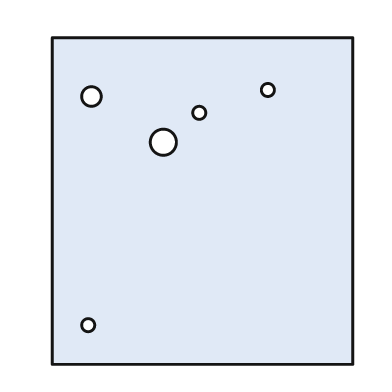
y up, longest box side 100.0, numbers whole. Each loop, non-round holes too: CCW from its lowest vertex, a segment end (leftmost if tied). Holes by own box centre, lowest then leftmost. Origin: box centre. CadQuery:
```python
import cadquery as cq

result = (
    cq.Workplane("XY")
    .moveTo(-46.0, -50.0)
    .lineTo(46.0, -50.0)
    .lineTo(46.0, 50.0)
    .lineTo(-46.0, 50.0)
    .close()
    .moveTo(-35.0, -38.0)
    .circle(2.0)
    .moveTo(-12.0, 18.0)
    .circle(4.0)
    .moveTo(-1.0, 27.0)
    .circle(2.0)
    .moveTo(-34.0, 32.0)
    .circle(3.0)
    .moveTo(20.0, 34.0)
    .circle(2.0)
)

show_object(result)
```